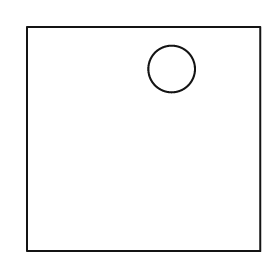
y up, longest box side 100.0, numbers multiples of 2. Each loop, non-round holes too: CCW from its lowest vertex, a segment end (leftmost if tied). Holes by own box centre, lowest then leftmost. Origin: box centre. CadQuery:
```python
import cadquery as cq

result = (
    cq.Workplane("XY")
    .moveTo(-50.0, -48.0)
    .lineTo(50.0, -48.0)
    .lineTo(50.0, 48.0)
    .lineTo(-50.0, 48.0)
    .close()
    .moveTo(12.0, 30.0)
    .circle(10.0)
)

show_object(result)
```